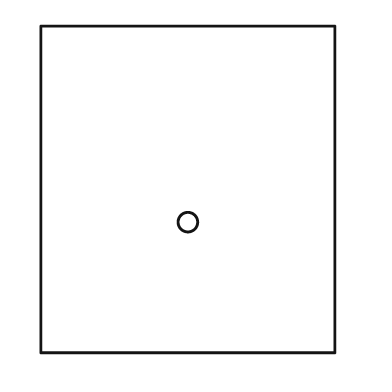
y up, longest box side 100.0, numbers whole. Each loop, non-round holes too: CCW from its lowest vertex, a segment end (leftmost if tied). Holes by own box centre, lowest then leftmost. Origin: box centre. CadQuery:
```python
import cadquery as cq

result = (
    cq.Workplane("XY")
    .moveTo(-45.0, -50.0)
    .lineTo(45.0, -50.0)
    .lineTo(45.0, 50.0)
    .lineTo(-45.0, 50.0)
    .close()
    .moveTo(0.0, -10.0)
    .circle(3.0)
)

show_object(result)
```